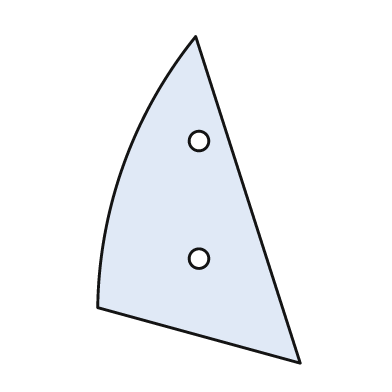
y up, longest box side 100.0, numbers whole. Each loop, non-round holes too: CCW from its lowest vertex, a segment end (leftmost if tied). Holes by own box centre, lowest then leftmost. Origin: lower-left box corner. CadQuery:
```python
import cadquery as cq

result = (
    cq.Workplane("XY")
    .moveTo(62.0, 0.0)
    .lineTo(30.0, 100.0)
    .threePointArc((8.0, 61.0), (0.0, 17.0))
    .close()
    .moveTo(31.0, 32.0)
    .circle(3.0)
    .moveTo(31.0, 68.0)
    .circle(3.0)
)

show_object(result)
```